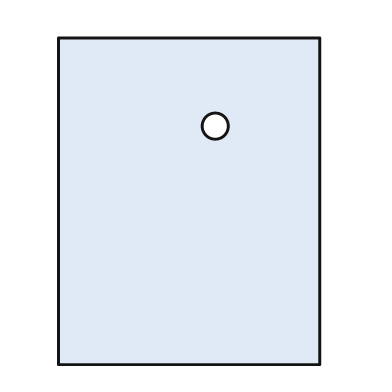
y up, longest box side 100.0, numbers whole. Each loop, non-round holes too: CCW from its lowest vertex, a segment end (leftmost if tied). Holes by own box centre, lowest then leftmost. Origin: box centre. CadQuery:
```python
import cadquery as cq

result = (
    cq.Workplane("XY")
    .moveTo(-40.0, -50.0)
    .lineTo(40.0, -50.0)
    .lineTo(40.0, 50.0)
    .lineTo(-40.0, 50.0)
    .close()
    .moveTo(8.0, 23.0)
    .circle(4.0)
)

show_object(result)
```